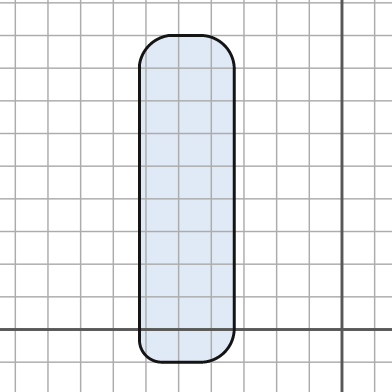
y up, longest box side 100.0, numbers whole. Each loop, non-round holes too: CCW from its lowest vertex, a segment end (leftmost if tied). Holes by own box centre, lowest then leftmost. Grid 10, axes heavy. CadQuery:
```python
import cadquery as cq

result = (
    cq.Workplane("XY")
    .moveTo(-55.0, -10.0)
    .lineTo(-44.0, -10.0)
    .threePointArc((-36.0, -7.0), (-33.0, 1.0))
    .lineTo(-33.0, 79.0)
    .threePointArc((-36.0, 87.0), (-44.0, 90.0))
    .lineTo(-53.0, 90.0)
    .threePointArc((-59.0, 87.0), (-62.0, 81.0))
    .lineTo(-62.0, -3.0)
    .threePointArc((-60.0, -8.0), (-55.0, -10.0))
    .close()
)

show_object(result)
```